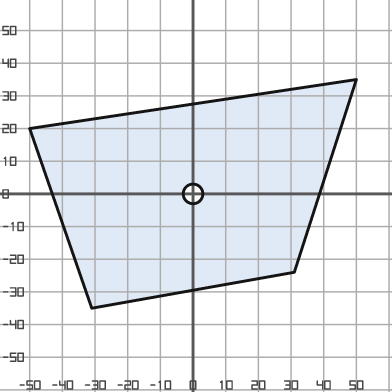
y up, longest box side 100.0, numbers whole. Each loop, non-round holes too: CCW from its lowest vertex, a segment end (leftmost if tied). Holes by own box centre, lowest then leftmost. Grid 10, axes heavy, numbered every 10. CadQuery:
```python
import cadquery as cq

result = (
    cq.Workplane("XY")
    .moveTo(-31.0, -35.0)
    .lineTo(31.0, -24.0)
    .lineTo(50.0, 35.0)
    .lineTo(-50.0, 20.0)
    .close()
    .moveTo(0.0, 0.0)
    .circle(3.0)
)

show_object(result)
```